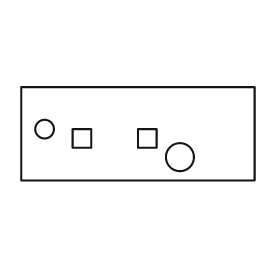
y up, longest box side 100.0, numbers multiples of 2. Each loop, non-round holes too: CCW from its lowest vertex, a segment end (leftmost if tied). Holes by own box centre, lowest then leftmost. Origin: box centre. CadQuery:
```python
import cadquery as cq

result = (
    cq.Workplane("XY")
    .moveTo(-50.0, -20.0)
    .lineTo(50.0, -20.0)
    .lineTo(50.0, 20.0)
    .lineTo(-50.0, 20.0)
    .close()
    .moveTo(18.0, -10.0)
    .circle(6.0)
    .moveTo(-28.0, -6.0)
    .lineTo(-20.0, -6.0)
    .lineTo(-20.0, 2.0)
    .lineTo(-28.0, 2.0)
    .close()
    .moveTo(0.0, -6.0)
    .lineTo(8.0, -6.0)
    .lineTo(8.0, 2.0)
    .lineTo(0.0, 2.0)
    .close()
    .moveTo(-40.0, 2.0)
    .circle(4.0)
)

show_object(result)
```